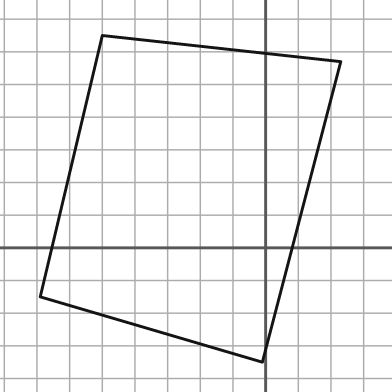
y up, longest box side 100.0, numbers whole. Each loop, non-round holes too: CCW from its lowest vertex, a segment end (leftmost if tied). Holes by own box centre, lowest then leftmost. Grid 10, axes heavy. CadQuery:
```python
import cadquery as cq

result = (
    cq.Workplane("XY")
    .moveTo(-1.0, -35.0)
    .lineTo(23.0, 57.0)
    .lineTo(-50.0, 65.0)
    .lineTo(-69.0, -15.0)
    .close()
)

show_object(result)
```